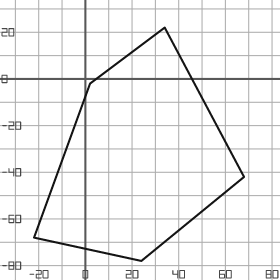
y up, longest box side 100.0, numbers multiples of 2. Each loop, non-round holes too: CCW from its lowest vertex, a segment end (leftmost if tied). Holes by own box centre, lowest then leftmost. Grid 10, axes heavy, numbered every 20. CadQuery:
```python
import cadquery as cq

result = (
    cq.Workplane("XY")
    .moveTo(24.0, -78.0)
    .lineTo(68.0, -42.0)
    .lineTo(34.0, 22.0)
    .lineTo(2.0, -2.0)
    .lineTo(-22.0, -68.0)
    .close()
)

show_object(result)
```